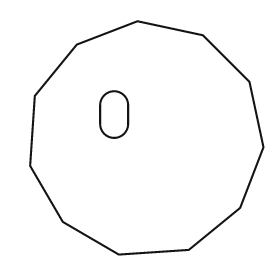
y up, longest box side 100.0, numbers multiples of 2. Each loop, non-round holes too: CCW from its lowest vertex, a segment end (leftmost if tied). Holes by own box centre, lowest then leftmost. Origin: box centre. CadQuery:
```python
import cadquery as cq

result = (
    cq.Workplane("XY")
    .moveTo(-12.0, -50.0)
    .lineTo(18.0, -48.0)
    .lineTo(40.0, -30.0)
    .lineTo(50.0, -4.0)
    .lineTo(44.0, 24.0)
    .lineTo(24.0, 44.0)
    .lineTo(-4.0, 50.0)
    .lineTo(-30.0, 40.0)
    .lineTo(-48.0, 18.0)
    .lineTo(-50.0, -12.0)
    .lineTo(-36.0, -36.0)
    .close()
    .moveTo(-20.0, 6.0)
    .threePointArc((-14.0, 0.0), (-8.0, 6.0))
    .lineTo(-8.0, 14.0)
    .threePointArc((-14.0, 20.0), (-20.0, 14.0))
    .close()
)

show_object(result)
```